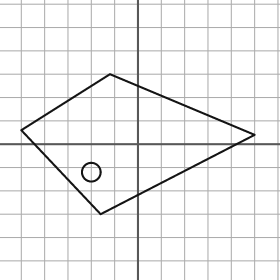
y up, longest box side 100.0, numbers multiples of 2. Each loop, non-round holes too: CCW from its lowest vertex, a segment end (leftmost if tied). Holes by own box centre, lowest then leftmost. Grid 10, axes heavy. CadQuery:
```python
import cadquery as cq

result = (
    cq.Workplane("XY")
    .moveTo(-16.0, -30.0)
    .lineTo(50.0, 4.0)
    .lineTo(-12.0, 30.0)
    .lineTo(-50.0, 6.0)
    .close()
    .moveTo(-20.0, -12.0)
    .circle(4.0)
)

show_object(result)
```